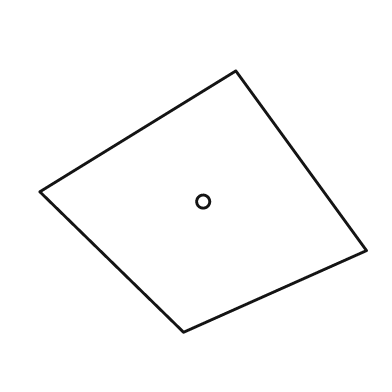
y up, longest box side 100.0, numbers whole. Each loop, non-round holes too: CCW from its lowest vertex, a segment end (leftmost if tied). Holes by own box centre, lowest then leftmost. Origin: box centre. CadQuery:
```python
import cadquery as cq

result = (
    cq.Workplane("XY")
    .moveTo(-6.0, -40.0)
    .lineTo(50.0, -15.0)
    .lineTo(10.0, 40.0)
    .lineTo(-50.0, 3.0)
    .close()
    .moveTo(0.0, 0.0)
    .circle(2.0)
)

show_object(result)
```